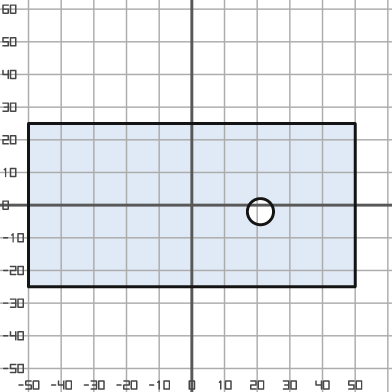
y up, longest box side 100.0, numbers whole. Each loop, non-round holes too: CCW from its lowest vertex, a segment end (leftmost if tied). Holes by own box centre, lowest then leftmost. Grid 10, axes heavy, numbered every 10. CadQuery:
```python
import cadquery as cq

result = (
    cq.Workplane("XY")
    .moveTo(-50.0, -25.0)
    .lineTo(50.0, -25.0)
    .lineTo(50.0, 25.0)
    .lineTo(-50.0, 25.0)
    .close()
    .moveTo(21.0, -2.0)
    .circle(4.0)
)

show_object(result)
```